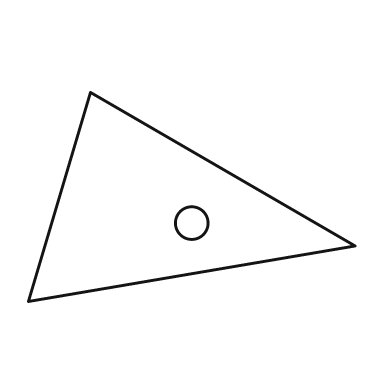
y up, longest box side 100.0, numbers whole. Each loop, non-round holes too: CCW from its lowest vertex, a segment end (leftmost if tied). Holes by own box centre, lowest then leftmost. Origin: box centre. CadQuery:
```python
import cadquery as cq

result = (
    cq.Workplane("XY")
    .moveTo(-50.0, -32.0)
    .lineTo(50.0, -15.0)
    .lineTo(-31.0, 32.0)
    .close()
    .moveTo(0.0, -8.0)
    .circle(5.0)
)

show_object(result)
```